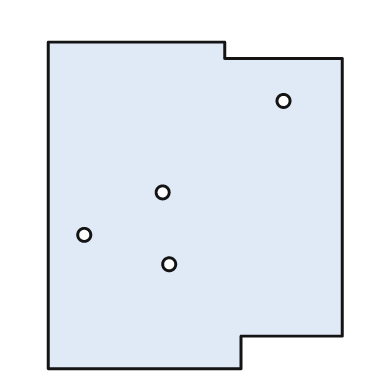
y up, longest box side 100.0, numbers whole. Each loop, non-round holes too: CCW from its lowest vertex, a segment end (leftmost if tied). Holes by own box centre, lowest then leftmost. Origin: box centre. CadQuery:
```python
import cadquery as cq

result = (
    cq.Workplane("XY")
    .moveTo(-45.0, -50.0)
    .lineTo(14.0, -50.0)
    .lineTo(14.0, -40.0)
    .lineTo(45.0, -40.0)
    .lineTo(45.0, 45.0)
    .lineTo(9.0, 45.0)
    .lineTo(9.0, 50.0)
    .lineTo(-45.0, 50.0)
    .close()
    .moveTo(-8.0, -18.0)
    .circle(2.0)
    .moveTo(-34.0, -9.0)
    .circle(2.0)
    .moveTo(-10.0, 4.0)
    .circle(2.0)
    .moveTo(27.0, 32.0)
    .circle(2.0)
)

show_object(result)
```